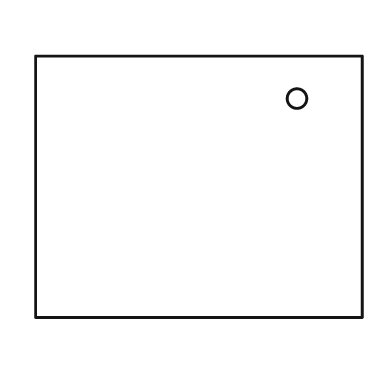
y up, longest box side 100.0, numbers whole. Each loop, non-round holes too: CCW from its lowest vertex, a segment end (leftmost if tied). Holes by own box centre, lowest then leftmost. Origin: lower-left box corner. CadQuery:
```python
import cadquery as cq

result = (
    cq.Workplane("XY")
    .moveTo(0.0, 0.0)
    .lineTo(100.0, 0.0)
    .lineTo(100.0, 80.0)
    .lineTo(0.0, 80.0)
    .close()
    .moveTo(80.0, 67.0)
    .circle(3.0)
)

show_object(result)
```